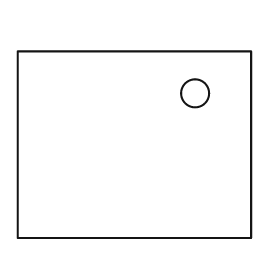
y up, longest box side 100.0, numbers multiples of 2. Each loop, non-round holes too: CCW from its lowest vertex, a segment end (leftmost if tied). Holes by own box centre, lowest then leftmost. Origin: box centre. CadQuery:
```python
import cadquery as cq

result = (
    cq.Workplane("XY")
    .moveTo(-50.0, -40.0)
    .lineTo(50.0, -40.0)
    .lineTo(50.0, 40.0)
    .lineTo(-50.0, 40.0)
    .close()
    .moveTo(26.0, 22.0)
    .circle(6.0)
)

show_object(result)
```